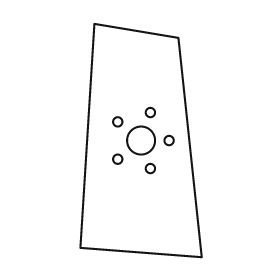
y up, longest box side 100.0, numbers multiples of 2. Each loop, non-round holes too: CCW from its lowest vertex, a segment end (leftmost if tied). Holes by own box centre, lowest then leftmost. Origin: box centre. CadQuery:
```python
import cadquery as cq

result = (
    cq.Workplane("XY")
    .moveTo(26.0, -50.0)
    .lineTo(16.0, 44.0)
    .lineTo(-20.0, 50.0)
    .lineTo(-26.0, -46.0)
    .close()
    .moveTo(4.0, -12.0)
    .circle(2.0)
    .moveTo(-10.0, -8.0)
    .circle(2.0)
    .moveTo(0.0, 0.0)
    .circle(6.0)
    .moveTo(12.0, 0.0)
    .circle(2.0)
    .moveTo(-10.0, 8.0)
    .circle(2.0)
    .moveTo(4.0, 12.0)
    .circle(2.0)
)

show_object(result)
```